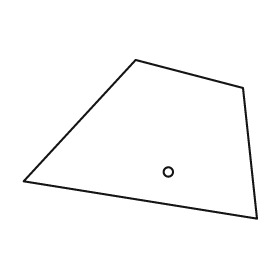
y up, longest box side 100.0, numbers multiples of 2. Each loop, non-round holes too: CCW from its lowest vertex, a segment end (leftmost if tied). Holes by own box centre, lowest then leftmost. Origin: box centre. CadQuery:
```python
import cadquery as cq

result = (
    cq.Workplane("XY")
    .moveTo(50.0, -34.0)
    .lineTo(44.0, 22.0)
    .lineTo(-2.0, 34.0)
    .lineTo(-50.0, -18.0)
    .close()
    .moveTo(12.0, -14.0)
    .circle(2.0)
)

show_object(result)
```